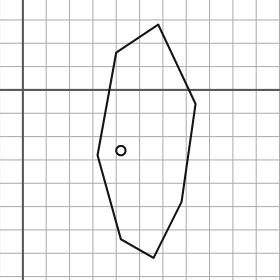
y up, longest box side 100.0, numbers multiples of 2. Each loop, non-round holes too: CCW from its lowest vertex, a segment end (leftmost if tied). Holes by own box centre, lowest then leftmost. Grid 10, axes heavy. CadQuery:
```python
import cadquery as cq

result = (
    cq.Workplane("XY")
    .moveTo(56.0, -72.0)
    .lineTo(68.0, -48.0)
    .lineTo(74.0, -6.0)
    .lineTo(58.0, 28.0)
    .lineTo(40.0, 16.0)
    .lineTo(32.0, -28.0)
    .lineTo(42.0, -64.0)
    .close()
    .moveTo(42.0, -26.0)
    .circle(2.0)
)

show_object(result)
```